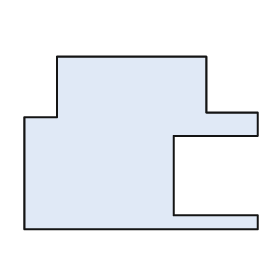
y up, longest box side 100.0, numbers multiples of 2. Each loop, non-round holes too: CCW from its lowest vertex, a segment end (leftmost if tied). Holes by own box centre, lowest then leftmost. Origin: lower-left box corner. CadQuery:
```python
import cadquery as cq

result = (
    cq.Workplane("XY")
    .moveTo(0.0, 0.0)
    .lineTo(100.0, 0.0)
    .lineTo(100.0, 6.0)
    .lineTo(64.0, 6.0)
    .lineTo(64.0, 40.0)
    .lineTo(100.0, 40.0)
    .lineTo(100.0, 50.0)
    .lineTo(78.0, 50.0)
    .lineTo(78.0, 74.0)
    .lineTo(14.0, 74.0)
    .lineTo(14.0, 48.0)
    .lineTo(0.0, 48.0)
    .close()
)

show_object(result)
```